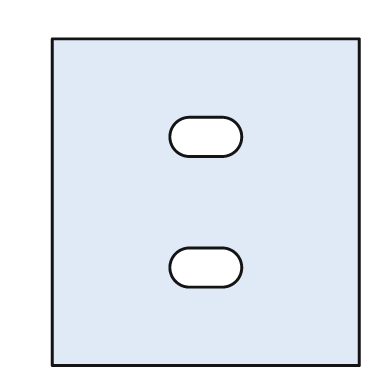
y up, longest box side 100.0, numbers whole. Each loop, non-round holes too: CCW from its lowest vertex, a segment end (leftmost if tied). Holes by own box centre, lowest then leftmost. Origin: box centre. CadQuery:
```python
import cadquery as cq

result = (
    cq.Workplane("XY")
    .moveTo(-47.0, -50.0)
    .lineTo(47.0, -50.0)
    .lineTo(47.0, 50.0)
    .lineTo(-47.0, 50.0)
    .close()
    .moveTo(-5.0, -26.0)
    .lineTo(5.0, -26.0)
    .threePointArc((11.0, -20.0), (5.0, -14.0))
    .lineTo(-5.0, -14.0)
    .threePointArc((-11.0, -20.0), (-5.0, -26.0))
    .close()
    .moveTo(-5.0, 14.0)
    .lineTo(5.0, 14.0)
    .threePointArc((11.0, 20.0), (5.0, 26.0))
    .lineTo(-5.0, 26.0)
    .threePointArc((-11.0, 20.0), (-5.0, 14.0))
    .close()
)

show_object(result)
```